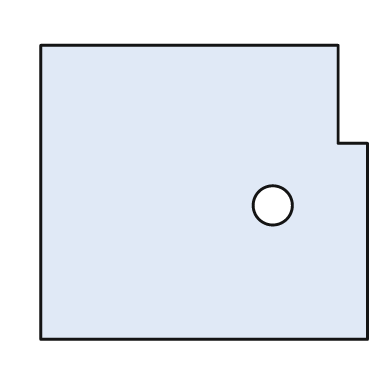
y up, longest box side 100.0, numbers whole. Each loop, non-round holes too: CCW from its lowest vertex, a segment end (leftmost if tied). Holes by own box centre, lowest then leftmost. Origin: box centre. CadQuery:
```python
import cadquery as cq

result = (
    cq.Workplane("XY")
    .moveTo(-50.0, -45.0)
    .lineTo(50.0, -45.0)
    .lineTo(50.0, 15.0)
    .lineTo(41.0, 15.0)
    .lineTo(41.0, 45.0)
    .lineTo(-50.0, 45.0)
    .close()
    .moveTo(21.0, -4.0)
    .circle(6.0)
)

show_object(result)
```